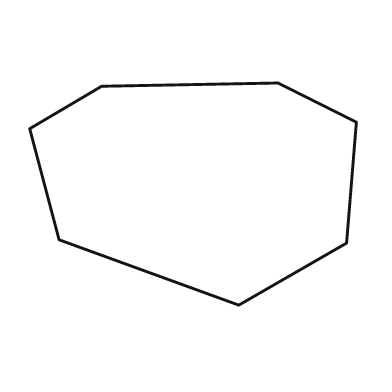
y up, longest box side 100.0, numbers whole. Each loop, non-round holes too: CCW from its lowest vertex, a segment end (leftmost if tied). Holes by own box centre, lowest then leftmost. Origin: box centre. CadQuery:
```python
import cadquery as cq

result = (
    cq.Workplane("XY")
    .moveTo(14.0, -34.0)
    .lineTo(47.0, -15.0)
    .lineTo(50.0, 22.0)
    .lineTo(26.0, 34.0)
    .lineTo(-28.0, 33.0)
    .lineTo(-50.0, 20.0)
    .lineTo(-41.0, -14.0)
    .close()
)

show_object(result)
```